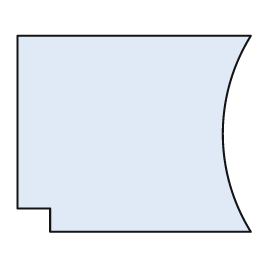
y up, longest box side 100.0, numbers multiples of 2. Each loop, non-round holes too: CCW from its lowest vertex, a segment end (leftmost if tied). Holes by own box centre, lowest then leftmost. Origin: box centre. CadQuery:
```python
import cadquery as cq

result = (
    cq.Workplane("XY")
    .moveTo(-36.0, -42.0)
    .lineTo(50.0, -42.0)
    .threePointArc((38.0, 0.0), (50.0, 42.0))
    .lineTo(-50.0, 42.0)
    .lineTo(-50.0, -32.0)
    .lineTo(-36.0, -32.0)
    .close()
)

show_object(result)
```